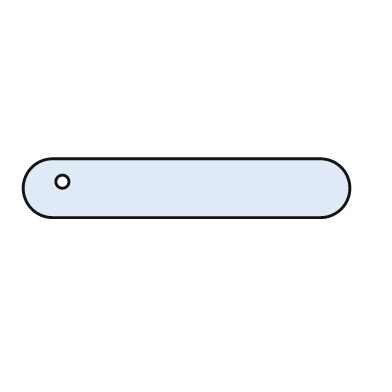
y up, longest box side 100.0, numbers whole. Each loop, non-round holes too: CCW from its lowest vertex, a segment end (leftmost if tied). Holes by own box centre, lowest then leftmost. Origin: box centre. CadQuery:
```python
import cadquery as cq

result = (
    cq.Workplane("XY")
    .moveTo(-41.0, -9.0)
    .lineTo(41.0, -9.0)
    .threePointArc((50.0, 0.0), (41.0, 9.0))
    .lineTo(-41.0, 9.0)
    .threePointArc((-50.0, 0.0), (-41.0, -9.0))
    .close()
    .moveTo(-38.0, 2.0)
    .circle(2.0)
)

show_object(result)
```